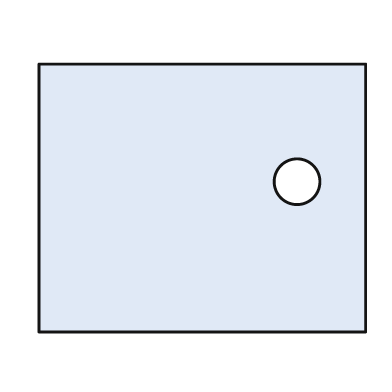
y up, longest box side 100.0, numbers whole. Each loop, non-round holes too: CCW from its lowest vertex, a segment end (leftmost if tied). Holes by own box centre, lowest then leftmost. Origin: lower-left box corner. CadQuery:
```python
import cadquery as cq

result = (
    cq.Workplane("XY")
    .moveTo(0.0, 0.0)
    .lineTo(100.0, 0.0)
    .lineTo(100.0, 82.0)
    .lineTo(0.0, 82.0)
    .close()
    .moveTo(79.0, 46.0)
    .circle(7.0)
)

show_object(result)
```